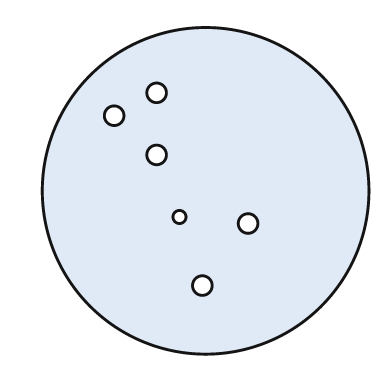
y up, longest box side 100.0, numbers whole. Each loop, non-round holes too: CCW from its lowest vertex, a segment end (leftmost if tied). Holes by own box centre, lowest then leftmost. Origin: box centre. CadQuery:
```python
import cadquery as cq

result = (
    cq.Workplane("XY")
    .moveTo(0.0, 0.0)
    .circle(50.0)
    .moveTo(-1.0, -29.0)
    .circle(3.0)
    .moveTo(13.0, -10.0)
    .circle(3.0)
    .moveTo(-8.0, -8.0)
    .circle(2.0)
    .moveTo(-15.0, 11.0)
    .circle(3.0)
    .moveTo(-28.0, 23.0)
    .circle(3.0)
    .moveTo(-15.0, 30.0)
    .circle(3.0)
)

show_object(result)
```